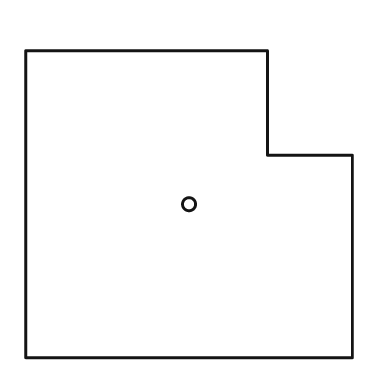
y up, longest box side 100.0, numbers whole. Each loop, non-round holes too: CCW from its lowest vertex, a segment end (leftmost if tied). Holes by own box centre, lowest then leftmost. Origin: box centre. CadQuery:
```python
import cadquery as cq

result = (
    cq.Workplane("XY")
    .moveTo(-50.0, -47.0)
    .lineTo(50.0, -47.0)
    .lineTo(50.0, 15.0)
    .lineTo(24.0, 15.0)
    .lineTo(24.0, 47.0)
    .lineTo(-50.0, 47.0)
    .close()
    .moveTo(0.0, 0.0)
    .circle(2.0)
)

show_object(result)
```